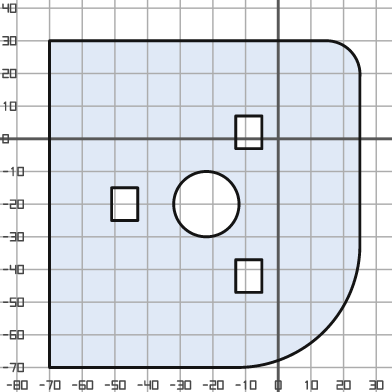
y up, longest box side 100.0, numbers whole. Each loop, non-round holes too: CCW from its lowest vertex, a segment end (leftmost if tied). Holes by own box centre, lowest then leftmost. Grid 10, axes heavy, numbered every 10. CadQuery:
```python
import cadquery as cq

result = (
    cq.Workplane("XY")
    .moveTo(-70.0, -70.0)
    .lineTo(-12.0, -70.0)
    .threePointArc((14.0, -59.0), (25.0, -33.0))
    .lineTo(25.0, 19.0)
    .threePointArc((22.0, 27.0), (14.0, 30.0))
    .lineTo(-70.0, 30.0)
    .close()
    .moveTo(-13.0, -47.0)
    .lineTo(-5.0, -47.0)
    .lineTo(-5.0, -37.0)
    .lineTo(-13.0, -37.0)
    .close()
    .moveTo(-51.0, -25.0)
    .lineTo(-43.0, -25.0)
    .lineTo(-43.0, -15.0)
    .lineTo(-51.0, -15.0)
    .close()
    .moveTo(-22.0, -20.0)
    .circle(10.0)
    .moveTo(-13.0, -3.0)
    .lineTo(-5.0, -3.0)
    .lineTo(-5.0, 7.0)
    .lineTo(-13.0, 7.0)
    .close()
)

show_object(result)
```